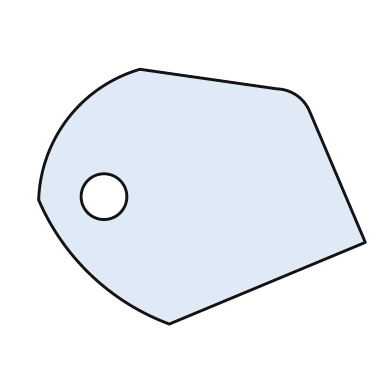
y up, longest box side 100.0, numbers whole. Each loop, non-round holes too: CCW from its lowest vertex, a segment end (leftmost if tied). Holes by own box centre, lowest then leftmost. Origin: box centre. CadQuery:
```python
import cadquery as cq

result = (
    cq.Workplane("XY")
    .moveTo(-10.0, -39.0)
    .lineTo(50.0, -14.0)
    .lineTo(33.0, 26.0)
    .threePointArc((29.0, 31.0), (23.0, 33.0))
    .lineTo(-19.0, 39.0)
    .threePointArc((-41.0, 24.0), (-50.0, -1.0))
    .threePointArc((-34.0, -24.0), (-10.0, -39.0))
    .close()
    .moveTo(-30.0, 0.0)
    .circle(7.0)
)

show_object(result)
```